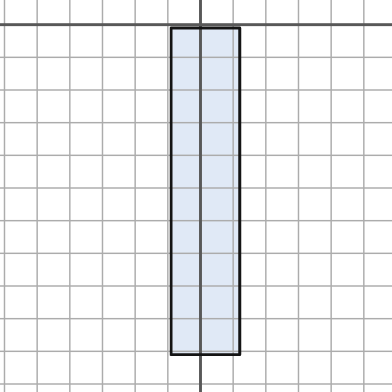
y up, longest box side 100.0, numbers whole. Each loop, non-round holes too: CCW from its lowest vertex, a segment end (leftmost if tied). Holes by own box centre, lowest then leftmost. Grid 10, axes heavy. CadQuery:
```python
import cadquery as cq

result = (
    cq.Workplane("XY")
    .moveTo(-9.0, -101.0)
    .lineTo(12.0, -101.0)
    .lineTo(12.0, -1.0)
    .lineTo(-9.0, -1.0)
    .close()
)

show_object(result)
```